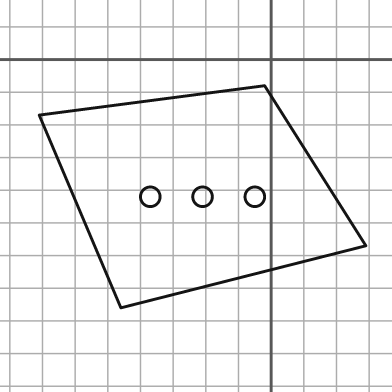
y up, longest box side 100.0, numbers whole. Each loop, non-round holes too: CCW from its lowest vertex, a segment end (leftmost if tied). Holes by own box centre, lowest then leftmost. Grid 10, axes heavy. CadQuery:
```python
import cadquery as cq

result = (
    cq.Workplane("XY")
    .moveTo(-46.0, -76.0)
    .lineTo(29.0, -57.0)
    .lineTo(-2.0, -8.0)
    .lineTo(-71.0, -17.0)
    .close()
    .moveTo(-37.0, -42.0)
    .circle(3.0)
    .moveTo(-21.0, -42.0)
    .circle(3.0)
    .moveTo(-5.0, -42.0)
    .circle(3.0)
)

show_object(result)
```